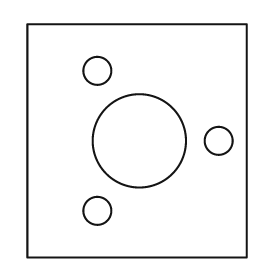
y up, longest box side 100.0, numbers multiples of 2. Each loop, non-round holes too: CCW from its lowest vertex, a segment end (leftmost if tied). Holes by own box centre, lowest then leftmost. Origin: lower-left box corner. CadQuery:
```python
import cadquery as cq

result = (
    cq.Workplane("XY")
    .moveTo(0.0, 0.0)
    .lineTo(94.0, 0.0)
    .lineTo(94.0, 100.0)
    .lineTo(0.0, 100.0)
    .close()
    .moveTo(30.0, 20.0)
    .circle(6.0)
    .moveTo(48.0, 50.0)
    .circle(20.0)
    .moveTo(82.0, 50.0)
    .circle(6.0)
    .moveTo(30.0, 80.0)
    .circle(6.0)
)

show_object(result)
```